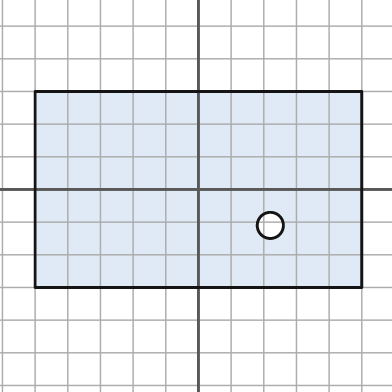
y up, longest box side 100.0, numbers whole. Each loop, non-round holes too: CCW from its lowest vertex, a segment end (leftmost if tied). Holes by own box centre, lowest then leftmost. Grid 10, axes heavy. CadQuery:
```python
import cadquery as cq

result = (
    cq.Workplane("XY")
    .moveTo(-50.0, -30.0)
    .lineTo(50.0, -30.0)
    .lineTo(50.0, 30.0)
    .lineTo(-50.0, 30.0)
    .close()
    .moveTo(22.0, -11.0)
    .circle(4.0)
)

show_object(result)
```